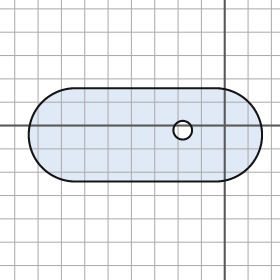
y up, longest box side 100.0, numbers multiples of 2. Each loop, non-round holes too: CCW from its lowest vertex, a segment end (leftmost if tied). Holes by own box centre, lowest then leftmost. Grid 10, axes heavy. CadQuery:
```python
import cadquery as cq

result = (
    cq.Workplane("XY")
    .moveTo(-64.0, -24.0)
    .lineTo(-4.0, -24.0)
    .threePointArc((16.0, -4.0), (-4.0, 16.0))
    .lineTo(-64.0, 16.0)
    .threePointArc((-84.0, -4.0), (-64.0, -24.0))
    .close()
    .moveTo(-18.0, -2.0)
    .circle(4.0)
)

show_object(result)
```